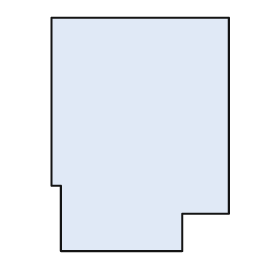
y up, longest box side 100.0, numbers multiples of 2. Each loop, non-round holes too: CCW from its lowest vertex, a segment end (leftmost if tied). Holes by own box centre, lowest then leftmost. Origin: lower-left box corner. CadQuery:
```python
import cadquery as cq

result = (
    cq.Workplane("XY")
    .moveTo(4.0, 0.0)
    .lineTo(56.0, 0.0)
    .lineTo(56.0, 16.0)
    .lineTo(76.0, 16.0)
    .lineTo(76.0, 100.0)
    .lineTo(0.0, 100.0)
    .lineTo(0.0, 28.0)
    .lineTo(4.0, 28.0)
    .close()
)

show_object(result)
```